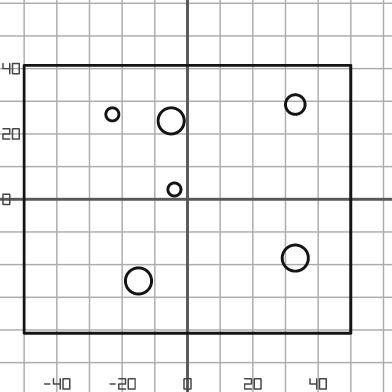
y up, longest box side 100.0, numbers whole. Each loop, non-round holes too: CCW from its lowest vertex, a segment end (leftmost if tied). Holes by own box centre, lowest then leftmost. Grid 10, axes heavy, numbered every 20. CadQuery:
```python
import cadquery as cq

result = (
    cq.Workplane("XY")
    .moveTo(-50.0, -41.0)
    .lineTo(50.0, -41.0)
    .lineTo(50.0, 41.0)
    .lineTo(-50.0, 41.0)
    .close()
    .moveTo(-15.0, -25.0)
    .circle(4.0)
    .moveTo(33.0, -18.0)
    .circle(4.0)
    .moveTo(-4.0, 3.0)
    .circle(2.0)
    .moveTo(-5.0, 24.0)
    .circle(4.0)
    .moveTo(-23.0, 26.0)
    .circle(2.0)
    .moveTo(33.0, 29.0)
    .circle(3.0)
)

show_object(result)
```